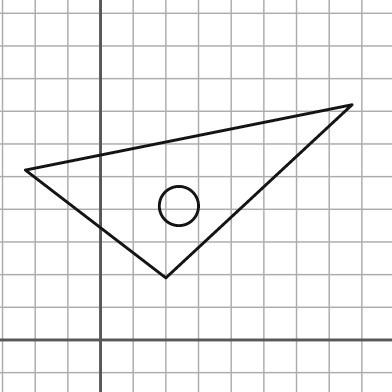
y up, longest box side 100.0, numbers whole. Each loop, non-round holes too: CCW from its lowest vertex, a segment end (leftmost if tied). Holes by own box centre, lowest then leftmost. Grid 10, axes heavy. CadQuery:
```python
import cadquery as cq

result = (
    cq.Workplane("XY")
    .moveTo(20.0, 19.0)
    .lineTo(77.0, 72.0)
    .lineTo(-23.0, 52.0)
    .close()
    .moveTo(24.0, 41.0)
    .circle(6.0)
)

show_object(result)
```